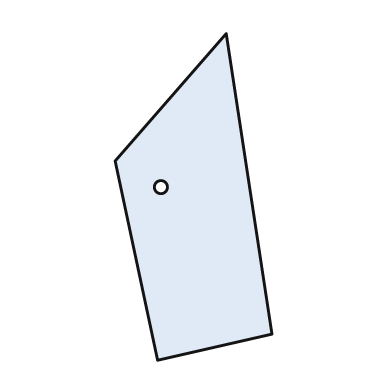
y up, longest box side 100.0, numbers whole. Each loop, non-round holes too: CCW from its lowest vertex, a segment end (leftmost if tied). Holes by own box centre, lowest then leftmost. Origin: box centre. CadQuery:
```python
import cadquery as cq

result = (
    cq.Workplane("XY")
    .moveTo(-11.0, -50.0)
    .lineTo(24.0, -42.0)
    .lineTo(10.0, 50.0)
    .lineTo(-24.0, 11.0)
    .close()
    .moveTo(-10.0, 3.0)
    .circle(2.0)
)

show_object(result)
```